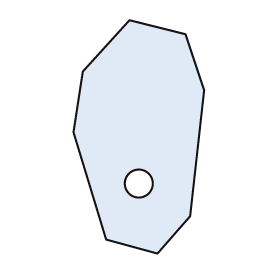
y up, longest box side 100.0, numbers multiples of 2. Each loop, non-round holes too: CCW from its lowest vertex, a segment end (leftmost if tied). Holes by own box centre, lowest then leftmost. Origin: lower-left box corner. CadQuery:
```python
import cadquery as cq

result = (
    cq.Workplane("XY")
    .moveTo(36.0, 0.0)
    .lineTo(50.0, 16.0)
    .lineTo(56.0, 70.0)
    .lineTo(48.0, 94.0)
    .lineTo(24.0, 100.0)
    .lineTo(4.0, 78.0)
    .lineTo(0.0, 52.0)
    .lineTo(14.0, 6.0)
    .close()
    .moveTo(28.0, 30.0)
    .circle(6.0)
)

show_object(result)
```